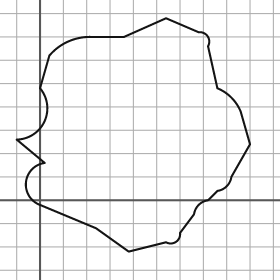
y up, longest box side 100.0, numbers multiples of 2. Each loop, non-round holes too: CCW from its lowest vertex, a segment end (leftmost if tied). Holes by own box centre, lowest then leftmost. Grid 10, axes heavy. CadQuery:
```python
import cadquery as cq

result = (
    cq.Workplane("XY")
    .moveTo(38.0, -22.0)
    .lineTo(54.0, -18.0)
    .threePointArc((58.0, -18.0), (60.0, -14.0))
    .lineTo(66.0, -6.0)
    .threePointArc((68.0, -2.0), (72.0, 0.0))
    .lineTo(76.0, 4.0)
    .threePointArc((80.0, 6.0), (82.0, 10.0))
    .lineTo(90.0, 24.0)
    .lineTo(86.0, 38.0)
    .threePointArc((82.0, 44.0), (76.0, 48.0))
    .lineTo(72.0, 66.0)
    .threePointArc((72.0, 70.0), (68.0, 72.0))
    .lineTo(54.0, 78.0)
    .lineTo(36.0, 70.0)
    .lineTo(22.0, 70.0)
    .threePointArc((12.0, 68.0), (4.0, 62.0))
    .lineTo(0.0, 48.0)
    .threePointArc((2.0, 34.0), (-10.0, 26.0))
    .lineTo(2.0, 16.0)
    .threePointArc((-6.0, 8.0), (0.0, -2.0))
    .lineTo(24.0, -12.0)
    .close()
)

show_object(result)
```